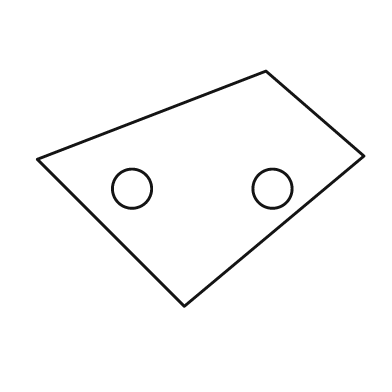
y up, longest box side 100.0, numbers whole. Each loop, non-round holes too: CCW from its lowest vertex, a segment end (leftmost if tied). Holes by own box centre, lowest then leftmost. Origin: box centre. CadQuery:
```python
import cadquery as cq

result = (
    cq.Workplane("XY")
    .moveTo(-5.0, -36.0)
    .lineTo(50.0, 10.0)
    .lineTo(20.0, 36.0)
    .lineTo(-50.0, 9.0)
    .close()
    .moveTo(-21.0, 0.0)
    .circle(6.0)
    .moveTo(22.0, 0.0)
    .circle(6.0)
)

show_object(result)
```